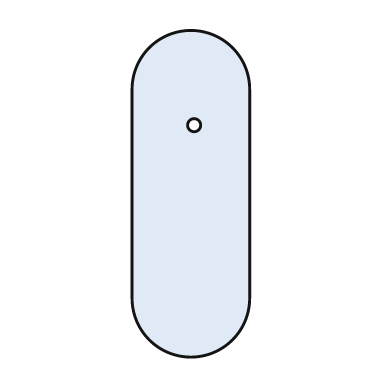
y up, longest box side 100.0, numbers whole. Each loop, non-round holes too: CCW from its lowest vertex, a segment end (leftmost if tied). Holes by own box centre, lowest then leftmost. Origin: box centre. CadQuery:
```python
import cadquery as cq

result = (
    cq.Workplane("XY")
    .moveTo(-18.0, -32.0)
    .threePointArc((0.0, -50.0), (18.0, -32.0))
    .lineTo(18.0, 32.0)
    .threePointArc((0.0, 50.0), (-18.0, 32.0))
    .close()
    .moveTo(1.0, 21.0)
    .circle(2.0)
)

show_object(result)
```